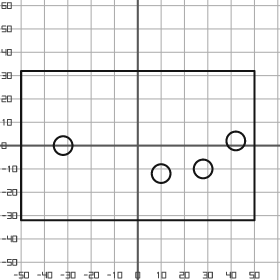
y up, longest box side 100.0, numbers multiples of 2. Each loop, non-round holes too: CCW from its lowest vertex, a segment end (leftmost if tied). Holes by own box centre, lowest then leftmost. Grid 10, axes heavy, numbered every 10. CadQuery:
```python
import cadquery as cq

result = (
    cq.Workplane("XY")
    .moveTo(-50.0, -32.0)
    .lineTo(50.0, -32.0)
    .lineTo(50.0, 32.0)
    .lineTo(-50.0, 32.0)
    .close()
    .moveTo(10.0, -12.0)
    .circle(4.0)
    .moveTo(28.0, -10.0)
    .circle(4.0)
    .moveTo(-32.0, 0.0)
    .circle(4.0)
    .moveTo(42.0, 2.0)
    .circle(4.0)
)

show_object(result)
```